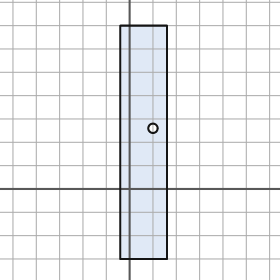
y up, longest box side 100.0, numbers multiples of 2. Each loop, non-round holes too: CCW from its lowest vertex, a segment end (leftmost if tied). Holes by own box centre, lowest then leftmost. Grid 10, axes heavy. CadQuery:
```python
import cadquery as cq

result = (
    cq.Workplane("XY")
    .moveTo(-4.0, -30.0)
    .lineTo(16.0, -30.0)
    .lineTo(16.0, 70.0)
    .lineTo(-4.0, 70.0)
    .close()
    .moveTo(10.0, 26.0)
    .circle(2.0)
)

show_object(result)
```